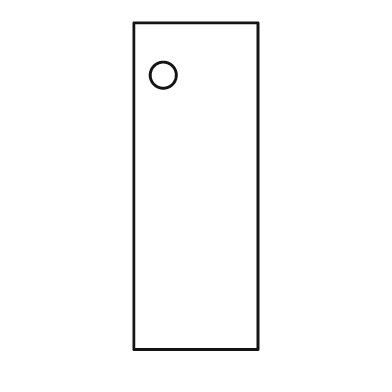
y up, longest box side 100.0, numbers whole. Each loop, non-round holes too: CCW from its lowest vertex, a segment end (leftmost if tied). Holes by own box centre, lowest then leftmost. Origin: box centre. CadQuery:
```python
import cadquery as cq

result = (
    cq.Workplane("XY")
    .moveTo(-19.0, -50.0)
    .lineTo(19.0, -50.0)
    .lineTo(19.0, 50.0)
    .lineTo(-19.0, 50.0)
    .close()
    .moveTo(-10.0, 34.0)
    .circle(4.0)
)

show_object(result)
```